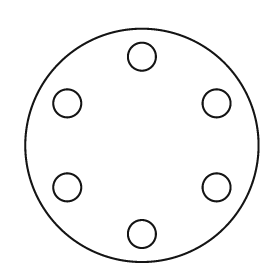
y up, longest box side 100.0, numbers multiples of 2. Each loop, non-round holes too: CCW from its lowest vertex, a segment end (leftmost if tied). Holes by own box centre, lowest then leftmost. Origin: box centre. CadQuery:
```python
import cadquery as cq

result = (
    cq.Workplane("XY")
    .moveTo(0.0, 0.0)
    .circle(50.0)
    .moveTo(0.0, -38.0)
    .circle(6.0)
    .moveTo(-32.0, -18.0)
    .circle(6.0)
    .moveTo(32.0, -18.0)
    .circle(6.0)
    .moveTo(-32.0, 18.0)
    .circle(6.0)
    .moveTo(32.0, 18.0)
    .circle(6.0)
    .moveTo(0.0, 38.0)
    .circle(6.0)
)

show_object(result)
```